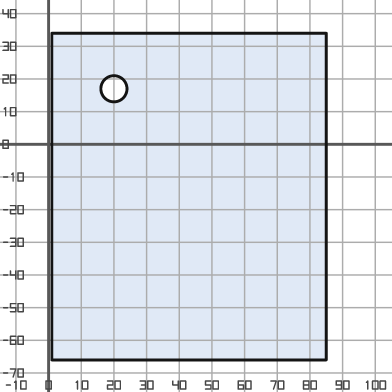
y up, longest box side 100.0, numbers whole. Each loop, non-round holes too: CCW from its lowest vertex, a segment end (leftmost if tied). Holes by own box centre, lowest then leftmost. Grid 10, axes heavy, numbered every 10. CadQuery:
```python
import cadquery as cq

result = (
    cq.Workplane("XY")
    .moveTo(1.0, -66.0)
    .lineTo(85.0, -66.0)
    .lineTo(85.0, 34.0)
    .lineTo(1.0, 34.0)
    .close()
    .moveTo(20.0, 17.0)
    .circle(4.0)
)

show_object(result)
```